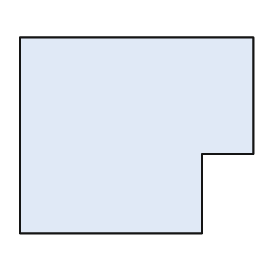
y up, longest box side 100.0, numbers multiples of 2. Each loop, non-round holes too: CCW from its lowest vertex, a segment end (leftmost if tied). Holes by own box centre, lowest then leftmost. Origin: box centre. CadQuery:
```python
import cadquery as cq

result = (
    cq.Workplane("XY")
    .moveTo(-50.0, -42.0)
    .lineTo(28.0, -42.0)
    .lineTo(28.0, -8.0)
    .lineTo(50.0, -8.0)
    .lineTo(50.0, 42.0)
    .lineTo(-50.0, 42.0)
    .close()
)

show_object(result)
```